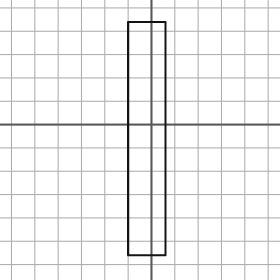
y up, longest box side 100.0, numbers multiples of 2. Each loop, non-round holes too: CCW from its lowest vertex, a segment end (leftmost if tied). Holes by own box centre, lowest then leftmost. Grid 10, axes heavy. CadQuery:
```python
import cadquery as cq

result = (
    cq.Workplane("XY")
    .moveTo(-10.0, -56.0)
    .lineTo(6.0, -56.0)
    .lineTo(6.0, 44.0)
    .lineTo(-10.0, 44.0)
    .close()
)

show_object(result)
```